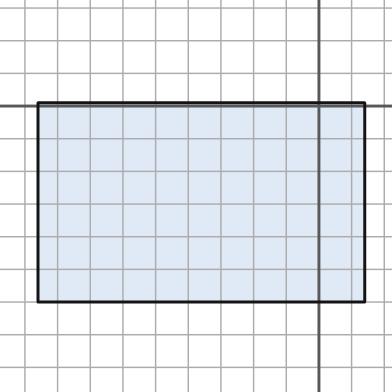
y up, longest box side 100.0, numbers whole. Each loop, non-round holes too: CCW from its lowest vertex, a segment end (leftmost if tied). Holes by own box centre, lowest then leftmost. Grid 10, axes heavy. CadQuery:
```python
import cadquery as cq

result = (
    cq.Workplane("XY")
    .moveTo(-86.0, -60.0)
    .lineTo(14.0, -60.0)
    .lineTo(14.0, 1.0)
    .lineTo(-86.0, 1.0)
    .close()
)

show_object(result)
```